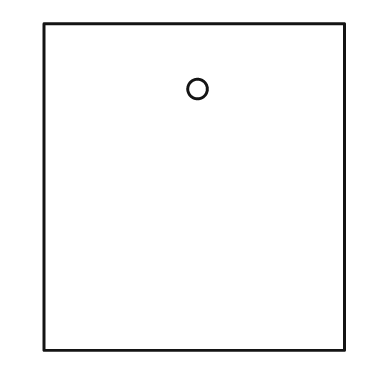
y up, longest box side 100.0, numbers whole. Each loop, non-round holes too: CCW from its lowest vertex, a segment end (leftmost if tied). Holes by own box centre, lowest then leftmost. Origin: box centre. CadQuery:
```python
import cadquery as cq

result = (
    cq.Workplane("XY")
    .moveTo(-46.0, -50.0)
    .lineTo(46.0, -50.0)
    .lineTo(46.0, 50.0)
    .lineTo(-46.0, 50.0)
    .close()
    .moveTo(1.0, 30.0)
    .circle(3.0)
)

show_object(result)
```